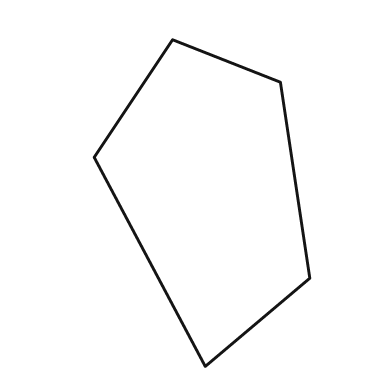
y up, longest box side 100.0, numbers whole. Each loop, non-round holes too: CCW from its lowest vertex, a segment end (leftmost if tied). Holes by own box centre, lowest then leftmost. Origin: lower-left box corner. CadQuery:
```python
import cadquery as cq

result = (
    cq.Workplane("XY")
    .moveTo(34.0, 0.0)
    .lineTo(66.0, 27.0)
    .lineTo(57.0, 87.0)
    .lineTo(24.0, 100.0)
    .lineTo(0.0, 64.0)
    .close()
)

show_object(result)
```